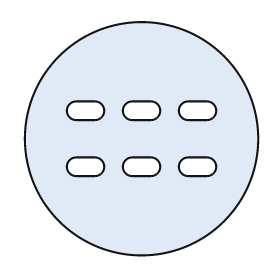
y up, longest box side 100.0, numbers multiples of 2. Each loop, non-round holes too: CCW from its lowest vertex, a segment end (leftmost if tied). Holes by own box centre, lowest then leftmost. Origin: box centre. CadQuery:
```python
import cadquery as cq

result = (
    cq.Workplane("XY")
    .moveTo(0.0, 0.0)
    .circle(50.0)
    .moveTo(-28.0, -16.0)
    .lineTo(-20.0, -16.0)
    .threePointArc((-16.0, -12.0), (-20.0, -8.0))
    .lineTo(-28.0, -8.0)
    .threePointArc((-32.0, -12.0), (-28.0, -16.0))
    .close()
    .moveTo(-4.0, -16.0)
    .lineTo(4.0, -16.0)
    .threePointArc((8.0, -12.0), (4.0, -8.0))
    .lineTo(-4.0, -8.0)
    .threePointArc((-8.0, -12.0), (-4.0, -16.0))
    .close()
    .moveTo(20.0, -16.0)
    .lineTo(28.0, -16.0)
    .threePointArc((32.0, -12.0), (28.0, -8.0))
    .lineTo(20.0, -8.0)
    .threePointArc((16.0, -12.0), (20.0, -16.0))
    .close()
    .moveTo(-28.0, 8.0)
    .lineTo(-20.0, 8.0)
    .threePointArc((-16.0, 12.0), (-20.0, 16.0))
    .lineTo(-28.0, 16.0)
    .threePointArc((-32.0, 12.0), (-28.0, 8.0))
    .close()
    .moveTo(-4.0, 8.0)
    .lineTo(4.0, 8.0)
    .threePointArc((8.0, 12.0), (4.0, 16.0))
    .lineTo(-4.0, 16.0)
    .threePointArc((-8.0, 12.0), (-4.0, 8.0))
    .close()
    .moveTo(20.0, 8.0)
    .lineTo(28.0, 8.0)
    .threePointArc((32.0, 12.0), (28.0, 16.0))
    .lineTo(20.0, 16.0)
    .threePointArc((16.0, 12.0), (20.0, 8.0))
    .close()
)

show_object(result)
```